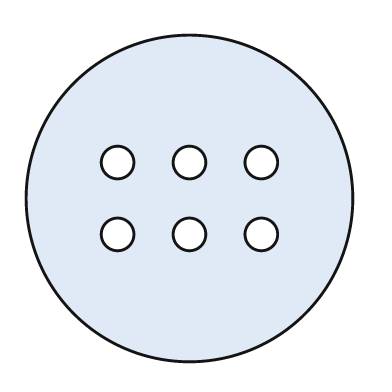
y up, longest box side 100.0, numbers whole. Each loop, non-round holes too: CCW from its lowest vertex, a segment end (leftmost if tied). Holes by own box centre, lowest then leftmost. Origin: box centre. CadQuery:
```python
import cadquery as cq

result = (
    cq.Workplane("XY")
    .moveTo(0.0, 0.0)
    .circle(50.0)
    .moveTo(-22.0, -11.0)
    .circle(5.0)
    .moveTo(0.0, -11.0)
    .circle(5.0)
    .moveTo(22.0, -11.0)
    .circle(5.0)
    .moveTo(-22.0, 11.0)
    .circle(5.0)
    .moveTo(0.0, 11.0)
    .circle(5.0)
    .moveTo(22.0, 11.0)
    .circle(5.0)
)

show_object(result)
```